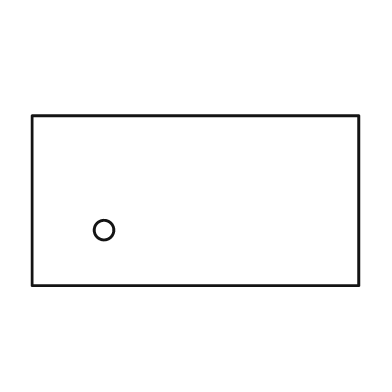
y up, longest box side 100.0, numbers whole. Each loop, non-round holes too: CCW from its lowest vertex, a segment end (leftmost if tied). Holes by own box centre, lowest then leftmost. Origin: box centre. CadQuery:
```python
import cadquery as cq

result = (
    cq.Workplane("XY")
    .moveTo(-50.0, -26.0)
    .lineTo(50.0, -26.0)
    .lineTo(50.0, 26.0)
    .lineTo(-50.0, 26.0)
    .close()
    .moveTo(-28.0, -9.0)
    .circle(3.0)
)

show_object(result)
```